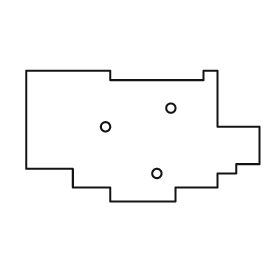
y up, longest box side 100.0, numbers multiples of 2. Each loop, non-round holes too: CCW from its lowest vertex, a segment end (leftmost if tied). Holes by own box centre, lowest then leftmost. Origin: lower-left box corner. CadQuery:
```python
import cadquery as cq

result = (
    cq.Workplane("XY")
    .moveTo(36.0, 0.0)
    .lineTo(64.0, 0.0)
    .lineTo(64.0, 6.0)
    .lineTo(82.0, 6.0)
    .lineTo(82.0, 12.0)
    .lineTo(90.0, 12.0)
    .lineTo(90.0, 16.0)
    .lineTo(100.0, 16.0)
    .lineTo(100.0, 32.0)
    .lineTo(82.0, 32.0)
    .lineTo(82.0, 56.0)
    .lineTo(76.0, 56.0)
    .lineTo(76.0, 52.0)
    .lineTo(36.0, 52.0)
    .lineTo(36.0, 56.0)
    .lineTo(0.0, 56.0)
    .lineTo(0.0, 14.0)
    .lineTo(20.0, 14.0)
    .lineTo(20.0, 6.0)
    .lineTo(36.0, 6.0)
    .close()
    .moveTo(56.0, 12.0)
    .circle(2.0)
    .moveTo(34.0, 32.0)
    .circle(2.0)
    .moveTo(62.0, 40.0)
    .circle(2.0)
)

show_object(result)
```